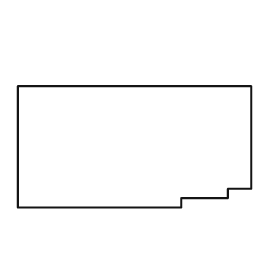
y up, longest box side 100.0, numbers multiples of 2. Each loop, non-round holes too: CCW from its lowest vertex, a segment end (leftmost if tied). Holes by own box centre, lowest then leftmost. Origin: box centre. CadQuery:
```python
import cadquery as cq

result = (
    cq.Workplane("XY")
    .moveTo(-50.0, -26.0)
    .lineTo(20.0, -26.0)
    .lineTo(20.0, -22.0)
    .lineTo(40.0, -22.0)
    .lineTo(40.0, -18.0)
    .lineTo(50.0, -18.0)
    .lineTo(50.0, 26.0)
    .lineTo(-50.0, 26.0)
    .close()
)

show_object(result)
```